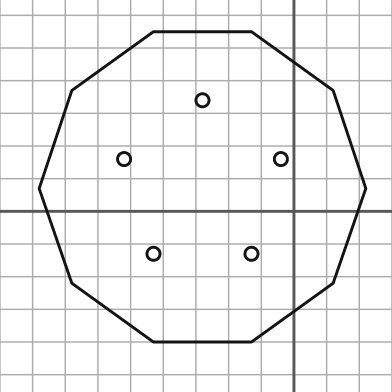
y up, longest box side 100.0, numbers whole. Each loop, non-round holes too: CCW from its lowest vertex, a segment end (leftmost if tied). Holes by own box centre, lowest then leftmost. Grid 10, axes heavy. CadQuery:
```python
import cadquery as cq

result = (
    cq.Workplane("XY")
    .moveTo(-43.0, -40.0)
    .lineTo(-13.0, -40.0)
    .lineTo(12.0, -22.0)
    .lineTo(22.0, 7.0)
    .lineTo(12.0, 37.0)
    .lineTo(-13.0, 55.0)
    .lineTo(-43.0, 55.0)
    .lineTo(-68.0, 37.0)
    .lineTo(-78.0, 7.0)
    .lineTo(-68.0, -22.0)
    .close()
    .moveTo(-43.0, -13.0)
    .circle(2.0)
    .moveTo(-13.0, -13.0)
    .circle(2.0)
    .moveTo(-52.0, 16.0)
    .circle(2.0)
    .moveTo(-4.0, 16.0)
    .circle(2.0)
    .moveTo(-28.0, 34.0)
    .circle(2.0)
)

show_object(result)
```